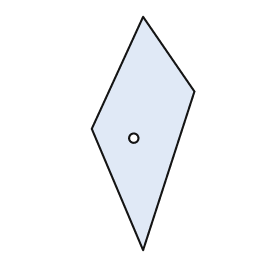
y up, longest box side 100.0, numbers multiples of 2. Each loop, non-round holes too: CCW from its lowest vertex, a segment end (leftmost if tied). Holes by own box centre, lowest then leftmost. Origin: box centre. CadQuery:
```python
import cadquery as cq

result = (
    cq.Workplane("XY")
    .moveTo(0.0, -50.0)
    .lineTo(22.0, 18.0)
    .lineTo(0.0, 50.0)
    .lineTo(-22.0, 2.0)
    .close()
    .moveTo(-4.0, -2.0)
    .circle(2.0)
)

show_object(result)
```